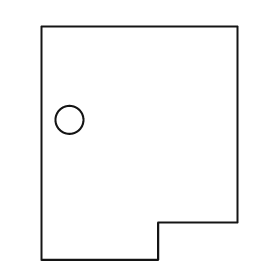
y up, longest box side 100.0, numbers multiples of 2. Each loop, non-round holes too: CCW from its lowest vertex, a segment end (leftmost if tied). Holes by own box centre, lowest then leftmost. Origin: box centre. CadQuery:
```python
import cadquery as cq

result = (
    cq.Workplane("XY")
    .moveTo(-42.0, -50.0)
    .lineTo(8.0, -50.0)
    .lineTo(8.0, -34.0)
    .lineTo(42.0, -34.0)
    .lineTo(42.0, 50.0)
    .lineTo(-42.0, 50.0)
    .close()
    .moveTo(-30.0, 10.0)
    .circle(6.0)
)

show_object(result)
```